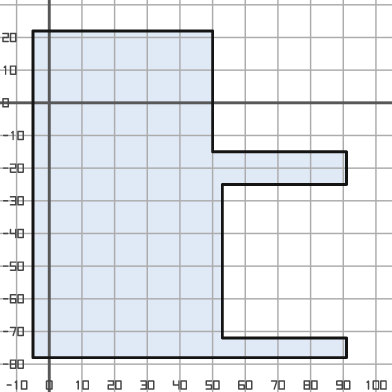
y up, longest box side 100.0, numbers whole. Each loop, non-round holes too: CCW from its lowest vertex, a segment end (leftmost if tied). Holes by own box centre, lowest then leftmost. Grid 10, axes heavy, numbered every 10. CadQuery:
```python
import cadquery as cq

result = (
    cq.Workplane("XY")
    .moveTo(-5.0, -78.0)
    .lineTo(91.0, -78.0)
    .lineTo(91.0, -72.0)
    .lineTo(53.0, -72.0)
    .lineTo(53.0, -25.0)
    .lineTo(91.0, -25.0)
    .lineTo(91.0, -15.0)
    .lineTo(50.0, -15.0)
    .lineTo(50.0, 22.0)
    .lineTo(-5.0, 22.0)
    .close()
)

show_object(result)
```